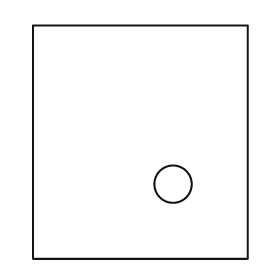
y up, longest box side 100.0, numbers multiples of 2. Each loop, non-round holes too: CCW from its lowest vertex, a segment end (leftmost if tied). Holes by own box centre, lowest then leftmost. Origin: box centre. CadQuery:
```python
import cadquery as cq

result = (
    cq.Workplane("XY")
    .moveTo(-46.0, -50.0)
    .lineTo(46.0, -50.0)
    .lineTo(46.0, 50.0)
    .lineTo(-46.0, 50.0)
    .close()
    .moveTo(14.0, -18.0)
    .circle(8.0)
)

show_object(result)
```